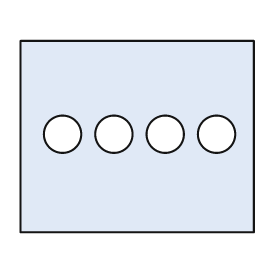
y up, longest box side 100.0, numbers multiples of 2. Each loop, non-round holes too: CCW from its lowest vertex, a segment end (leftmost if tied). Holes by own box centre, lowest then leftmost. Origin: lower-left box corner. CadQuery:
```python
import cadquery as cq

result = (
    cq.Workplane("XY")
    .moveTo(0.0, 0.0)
    .lineTo(100.0, 0.0)
    .lineTo(100.0, 82.0)
    .lineTo(0.0, 82.0)
    .close()
    .moveTo(18.0, 42.0)
    .circle(8.0)
    .moveTo(40.0, 42.0)
    .circle(8.0)
    .moveTo(62.0, 42.0)
    .circle(8.0)
    .moveTo(84.0, 42.0)
    .circle(8.0)
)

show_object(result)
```